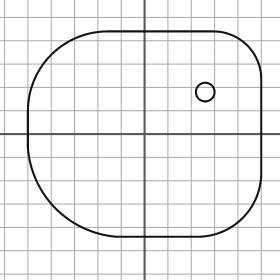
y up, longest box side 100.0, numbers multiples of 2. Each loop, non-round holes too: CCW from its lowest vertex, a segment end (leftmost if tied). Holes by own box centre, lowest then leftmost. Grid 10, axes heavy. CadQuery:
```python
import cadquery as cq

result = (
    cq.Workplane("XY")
    .moveTo(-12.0, -44.0)
    .lineTo(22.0, -44.0)
    .threePointArc((42.0, -36.0), (50.0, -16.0))
    .lineTo(50.0, 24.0)
    .threePointArc((44.0, 38.0), (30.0, 44.0))
    .lineTo(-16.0, 44.0)
    .threePointArc((-40.0, 34.0), (-50.0, 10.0))
    .lineTo(-50.0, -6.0)
    .threePointArc((-38.0, -32.0), (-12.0, -44.0))
    .close()
    .moveTo(26.0, 18.0)
    .circle(4.0)
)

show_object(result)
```